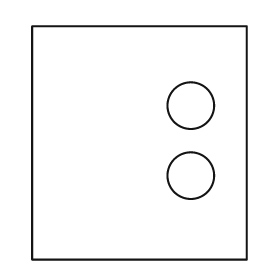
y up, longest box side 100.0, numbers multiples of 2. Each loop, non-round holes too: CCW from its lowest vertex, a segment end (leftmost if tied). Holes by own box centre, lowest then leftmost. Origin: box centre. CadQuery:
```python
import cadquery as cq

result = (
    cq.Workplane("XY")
    .moveTo(-46.0, -50.0)
    .lineTo(46.0, -50.0)
    .lineTo(46.0, 50.0)
    .lineTo(-46.0, 50.0)
    .close()
    .moveTo(22.0, -14.0)
    .circle(10.0)
    .moveTo(22.0, 16.0)
    .circle(10.0)
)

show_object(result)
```